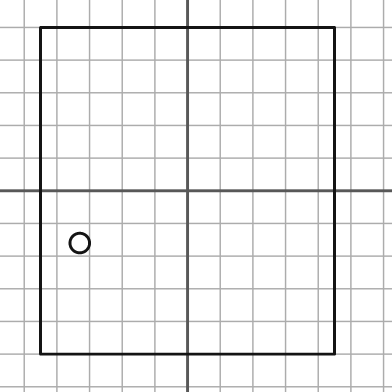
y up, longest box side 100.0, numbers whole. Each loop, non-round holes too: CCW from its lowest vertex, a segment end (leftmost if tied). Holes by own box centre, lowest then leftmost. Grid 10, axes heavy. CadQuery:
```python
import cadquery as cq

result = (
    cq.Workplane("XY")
    .moveTo(-45.0, -50.0)
    .lineTo(45.0, -50.0)
    .lineTo(45.0, 50.0)
    .lineTo(-45.0, 50.0)
    .close()
    .moveTo(-33.0, -16.0)
    .circle(3.0)
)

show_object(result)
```